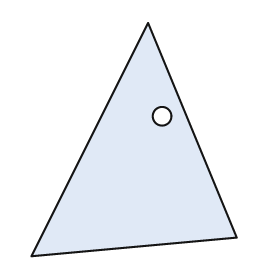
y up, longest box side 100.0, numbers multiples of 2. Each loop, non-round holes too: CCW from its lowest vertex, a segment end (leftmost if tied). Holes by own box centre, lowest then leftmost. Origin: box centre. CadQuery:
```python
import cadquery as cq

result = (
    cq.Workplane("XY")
    .moveTo(-44.0, -50.0)
    .lineTo(44.0, -42.0)
    .lineTo(6.0, 50.0)
    .close()
    .moveTo(12.0, 10.0)
    .circle(4.0)
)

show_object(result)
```